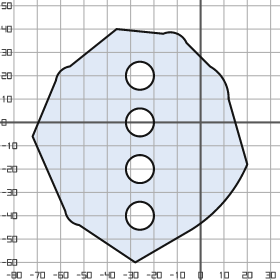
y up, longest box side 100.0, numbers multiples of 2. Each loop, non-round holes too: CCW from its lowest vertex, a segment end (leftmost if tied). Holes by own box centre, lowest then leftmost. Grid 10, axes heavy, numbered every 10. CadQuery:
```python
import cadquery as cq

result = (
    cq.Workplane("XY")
    .moveTo(-28.0, -60.0)
    .lineTo(-4.0, -46.0)
    .threePointArc((10.0, -34.0), (20.0, -18.0))
    .lineTo(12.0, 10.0)
    .threePointArc((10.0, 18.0), (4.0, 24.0))
    .lineTo(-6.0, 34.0)
    .threePointArc((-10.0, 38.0), (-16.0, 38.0))
    .lineTo(-36.0, 40.0)
    .lineTo(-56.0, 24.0)
    .threePointArc((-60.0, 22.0), (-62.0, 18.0))
    .lineTo(-72.0, -6.0)
    .lineTo(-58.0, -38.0)
    .threePointArc((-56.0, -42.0), (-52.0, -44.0))
    .close()
    .moveTo(-26.0, -40.0)
    .circle(6.0)
    .moveTo(-26.0, -20.0)
    .circle(6.0)
    .moveTo(-26.0, 0.0)
    .circle(6.0)
    .moveTo(-26.0, 20.0)
    .circle(6.0)
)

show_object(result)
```